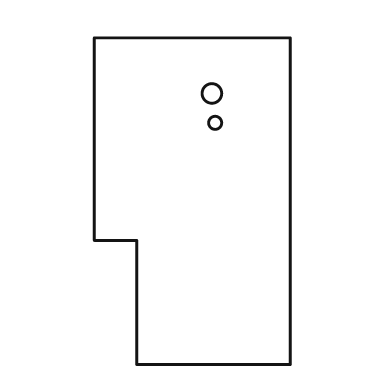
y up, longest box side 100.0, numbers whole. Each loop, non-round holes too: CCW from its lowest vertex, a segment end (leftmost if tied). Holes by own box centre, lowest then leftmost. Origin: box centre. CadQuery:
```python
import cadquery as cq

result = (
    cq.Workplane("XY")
    .moveTo(-17.0, -50.0)
    .lineTo(30.0, -50.0)
    .lineTo(30.0, 50.0)
    .lineTo(-30.0, 50.0)
    .lineTo(-30.0, -12.0)
    .lineTo(-17.0, -12.0)
    .close()
    .moveTo(7.0, 24.0)
    .circle(2.0)
    .moveTo(6.0, 33.0)
    .circle(3.0)
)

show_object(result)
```